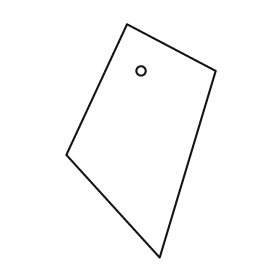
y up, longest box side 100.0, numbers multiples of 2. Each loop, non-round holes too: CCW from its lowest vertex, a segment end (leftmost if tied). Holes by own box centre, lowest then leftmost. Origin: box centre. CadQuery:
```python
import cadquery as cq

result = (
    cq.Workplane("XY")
    .moveTo(8.0, -50.0)
    .lineTo(32.0, 30.0)
    .lineTo(-6.0, 50.0)
    .lineTo(-32.0, -6.0)
    .close()
    .moveTo(0.0, 30.0)
    .circle(2.0)
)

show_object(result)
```